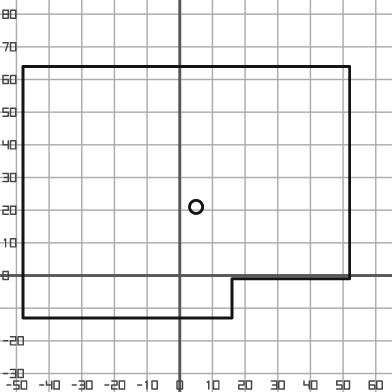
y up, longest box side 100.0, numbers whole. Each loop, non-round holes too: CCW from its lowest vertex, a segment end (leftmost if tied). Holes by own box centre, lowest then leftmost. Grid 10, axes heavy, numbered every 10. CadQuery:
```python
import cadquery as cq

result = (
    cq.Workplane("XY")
    .moveTo(-48.0, -13.0)
    .lineTo(16.0, -13.0)
    .lineTo(16.0, -1.0)
    .lineTo(52.0, -1.0)
    .lineTo(52.0, 64.0)
    .lineTo(-48.0, 64.0)
    .close()
    .moveTo(5.0, 21.0)
    .circle(2.0)
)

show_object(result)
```